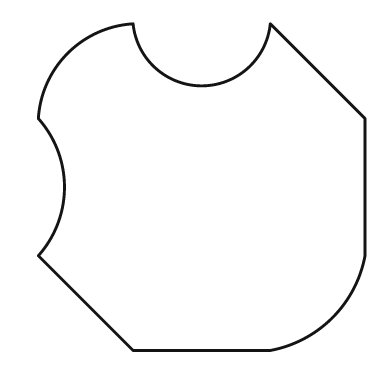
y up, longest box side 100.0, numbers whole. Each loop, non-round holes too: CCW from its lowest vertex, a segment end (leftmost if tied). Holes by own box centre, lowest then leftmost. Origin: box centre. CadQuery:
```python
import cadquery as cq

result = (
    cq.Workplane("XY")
    .moveTo(-21.0, -50.0)
    .lineTo(21.0, -50.0)
    .threePointArc((40.0, -40.0), (50.0, -21.0))
    .lineTo(50.0, 21.0)
    .lineTo(21.0, 50.0)
    .threePointArc((0.0, 31.0), (-21.0, 50.0))
    .threePointArc((-41.0, 41.0), (-50.0, 21.0))
    .threePointArc((-42.0, 0.0), (-50.0, -21.0))
    .close()
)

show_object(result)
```